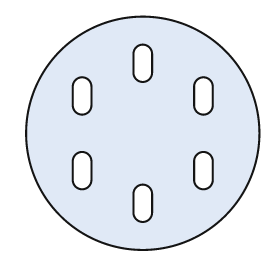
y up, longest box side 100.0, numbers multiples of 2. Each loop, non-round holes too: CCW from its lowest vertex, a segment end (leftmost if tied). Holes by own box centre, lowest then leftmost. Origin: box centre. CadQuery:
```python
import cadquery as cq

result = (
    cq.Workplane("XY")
    .moveTo(0.0, 0.0)
    .circle(50.0)
    .moveTo(-4.0, -34.0)
    .threePointArc((0.0, -38.0), (4.0, -34.0))
    .lineTo(4.0, -26.0)
    .threePointArc((0.0, -22.0), (-4.0, -26.0))
    .close()
    .moveTo(-30.0, -20.0)
    .threePointArc((-26.0, -24.0), (-22.0, -20.0))
    .lineTo(-22.0, -12.0)
    .threePointArc((-26.0, -8.0), (-30.0, -12.0))
    .close()
    .moveTo(22.0, -20.0)
    .threePointArc((26.0, -24.0), (30.0, -20.0))
    .lineTo(30.0, -12.0)
    .threePointArc((26.0, -8.0), (22.0, -12.0))
    .close()
    .moveTo(-30.0, 12.0)
    .threePointArc((-26.0, 8.0), (-22.0, 12.0))
    .lineTo(-22.0, 20.0)
    .threePointArc((-26.0, 24.0), (-30.0, 20.0))
    .close()
    .moveTo(22.0, 12.0)
    .threePointArc((26.0, 8.0), (30.0, 12.0))
    .lineTo(30.0, 20.0)
    .threePointArc((26.0, 24.0), (22.0, 20.0))
    .close()
    .moveTo(-4.0, 26.0)
    .threePointArc((0.0, 22.0), (4.0, 26.0))
    .lineTo(4.0, 34.0)
    .threePointArc((0.0, 38.0), (-4.0, 34.0))
    .close()
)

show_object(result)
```